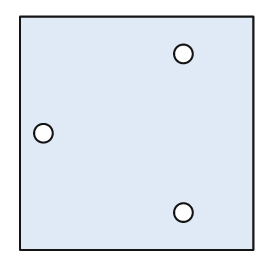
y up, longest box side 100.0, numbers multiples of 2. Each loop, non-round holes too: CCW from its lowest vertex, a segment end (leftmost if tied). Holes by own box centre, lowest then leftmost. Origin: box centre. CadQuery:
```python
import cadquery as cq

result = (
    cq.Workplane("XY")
    .moveTo(-50.0, -50.0)
    .lineTo(50.0, -50.0)
    .lineTo(50.0, 50.0)
    .lineTo(-50.0, 50.0)
    .close()
    .moveTo(20.0, -34.0)
    .circle(4.0)
    .moveTo(-40.0, 0.0)
    .circle(4.0)
    .moveTo(20.0, 34.0)
    .circle(4.0)
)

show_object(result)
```